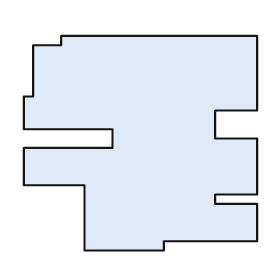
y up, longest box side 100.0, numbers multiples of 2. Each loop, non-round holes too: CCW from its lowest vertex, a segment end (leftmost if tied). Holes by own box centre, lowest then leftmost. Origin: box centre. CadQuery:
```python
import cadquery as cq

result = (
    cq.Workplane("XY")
    .moveTo(-24.0, -46.0)
    .lineTo(10.0, -46.0)
    .lineTo(10.0, -42.0)
    .lineTo(50.0, -42.0)
    .lineTo(50.0, -26.0)
    .lineTo(32.0, -26.0)
    .lineTo(32.0, -22.0)
    .lineTo(50.0, -22.0)
    .lineTo(50.0, 2.0)
    .lineTo(32.0, 2.0)
    .lineTo(32.0, 14.0)
    .lineTo(50.0, 14.0)
    .lineTo(50.0, 46.0)
    .lineTo(-34.0, 46.0)
    .lineTo(-34.0, 42.0)
    .lineTo(-46.0, 42.0)
    .lineTo(-46.0, 20.0)
    .lineTo(-50.0, 20.0)
    .lineTo(-50.0, 6.0)
    .lineTo(-12.0, 6.0)
    .lineTo(-12.0, -2.0)
    .lineTo(-50.0, -2.0)
    .lineTo(-50.0, -18.0)
    .lineTo(-24.0, -18.0)
    .close()
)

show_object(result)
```